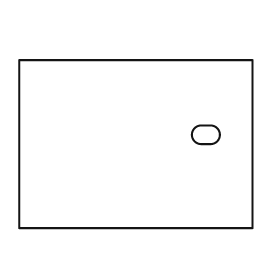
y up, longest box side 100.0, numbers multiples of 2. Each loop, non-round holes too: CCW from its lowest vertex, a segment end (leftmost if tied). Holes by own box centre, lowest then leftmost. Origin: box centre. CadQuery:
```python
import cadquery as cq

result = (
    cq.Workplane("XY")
    .moveTo(-50.0, -36.0)
    .lineTo(50.0, -36.0)
    .lineTo(50.0, 36.0)
    .lineTo(-50.0, 36.0)
    .close()
    .moveTo(28.0, 0.0)
    .lineTo(32.0, 0.0)
    .threePointArc((36.0, 4.0), (32.0, 8.0))
    .lineTo(28.0, 8.0)
    .threePointArc((24.0, 4.0), (28.0, 0.0))
    .close()
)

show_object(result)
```